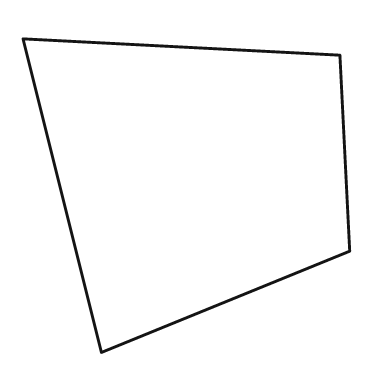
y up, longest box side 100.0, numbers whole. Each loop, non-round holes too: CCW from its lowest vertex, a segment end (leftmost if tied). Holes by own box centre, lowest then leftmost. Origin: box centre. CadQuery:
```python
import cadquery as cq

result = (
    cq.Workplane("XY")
    .moveTo(-26.0, -48.0)
    .lineTo(50.0, -17.0)
    .lineTo(47.0, 43.0)
    .lineTo(-50.0, 48.0)
    .close()
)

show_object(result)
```